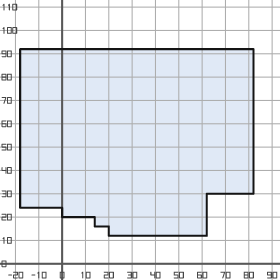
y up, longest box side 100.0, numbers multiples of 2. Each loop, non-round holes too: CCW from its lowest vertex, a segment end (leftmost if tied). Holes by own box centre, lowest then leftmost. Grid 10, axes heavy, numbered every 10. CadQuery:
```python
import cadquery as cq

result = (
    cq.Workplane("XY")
    .moveTo(20.0, 12.0)
    .lineTo(62.0, 12.0)
    .lineTo(62.0, 30.0)
    .lineTo(82.0, 30.0)
    .lineTo(82.0, 92.0)
    .lineTo(-18.0, 92.0)
    .lineTo(-18.0, 24.0)
    .lineTo(0.0, 24.0)
    .lineTo(0.0, 20.0)
    .lineTo(14.0, 20.0)
    .lineTo(14.0, 16.0)
    .lineTo(20.0, 16.0)
    .close()
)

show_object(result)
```